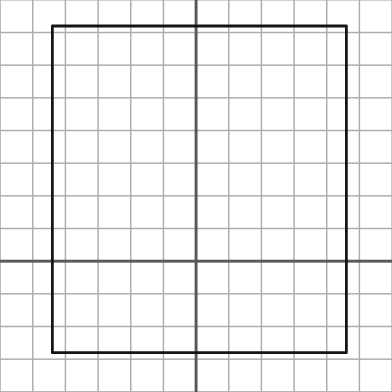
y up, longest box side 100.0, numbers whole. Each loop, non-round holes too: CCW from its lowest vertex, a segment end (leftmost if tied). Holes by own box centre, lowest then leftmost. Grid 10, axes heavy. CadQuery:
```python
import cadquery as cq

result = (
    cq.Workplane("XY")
    .moveTo(-44.0, -28.0)
    .lineTo(46.0, -28.0)
    .lineTo(46.0, 72.0)
    .lineTo(-44.0, 72.0)
    .close()
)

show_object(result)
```